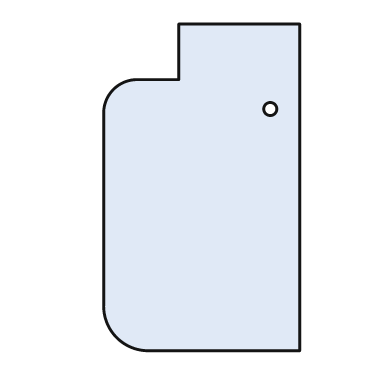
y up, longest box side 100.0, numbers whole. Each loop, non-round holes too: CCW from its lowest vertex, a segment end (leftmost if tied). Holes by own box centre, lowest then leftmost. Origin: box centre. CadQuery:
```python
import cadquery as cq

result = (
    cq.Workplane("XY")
    .moveTo(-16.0, -50.0)
    .lineTo(30.0, -50.0)
    .lineTo(30.0, 50.0)
    .lineTo(-7.0, 50.0)
    .lineTo(-7.0, 33.0)
    .lineTo(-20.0, 33.0)
    .threePointArc((-27.0, 30.0), (-30.0, 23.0))
    .lineTo(-30.0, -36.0)
    .threePointArc((-26.0, -46.0), (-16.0, -50.0))
    .close()
    .moveTo(21.0, 24.0)
    .circle(2.0)
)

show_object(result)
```